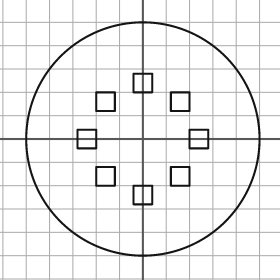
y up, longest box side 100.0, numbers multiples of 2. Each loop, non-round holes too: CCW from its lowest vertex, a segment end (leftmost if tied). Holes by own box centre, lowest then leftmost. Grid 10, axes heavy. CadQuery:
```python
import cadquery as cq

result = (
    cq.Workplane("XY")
    .moveTo(0.0, 0.0)
    .circle(50.0)
    .moveTo(-4.0, -28.0)
    .lineTo(4.0, -28.0)
    .lineTo(4.0, -20.0)
    .lineTo(-4.0, -20.0)
    .close()
    .moveTo(-20.0, -20.0)
    .lineTo(-12.0, -20.0)
    .lineTo(-12.0, -12.0)
    .lineTo(-20.0, -12.0)
    .close()
    .moveTo(12.0, -20.0)
    .lineTo(20.0, -20.0)
    .lineTo(20.0, -12.0)
    .lineTo(12.0, -12.0)
    .close()
    .moveTo(-28.0, -4.0)
    .lineTo(-20.0, -4.0)
    .lineTo(-20.0, 4.0)
    .lineTo(-28.0, 4.0)
    .close()
    .moveTo(20.0, -4.0)
    .lineTo(28.0, -4.0)
    .lineTo(28.0, 4.0)
    .lineTo(20.0, 4.0)
    .close()
    .moveTo(-20.0, 12.0)
    .lineTo(-12.0, 12.0)
    .lineTo(-12.0, 20.0)
    .lineTo(-20.0, 20.0)
    .close()
    .moveTo(12.0, 12.0)
    .lineTo(20.0, 12.0)
    .lineTo(20.0, 20.0)
    .lineTo(12.0, 20.0)
    .close()
    .moveTo(-4.0, 20.0)
    .lineTo(4.0, 20.0)
    .lineTo(4.0, 28.0)
    .lineTo(-4.0, 28.0)
    .close()
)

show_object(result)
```